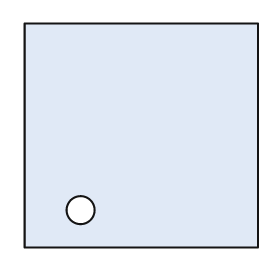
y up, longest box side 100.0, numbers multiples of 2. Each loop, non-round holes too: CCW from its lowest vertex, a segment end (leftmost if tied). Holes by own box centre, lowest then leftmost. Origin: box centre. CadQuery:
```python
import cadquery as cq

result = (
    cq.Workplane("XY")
    .moveTo(-50.0, -48.0)
    .lineTo(50.0, -48.0)
    .lineTo(50.0, 48.0)
    .lineTo(-50.0, 48.0)
    .close()
    .moveTo(-26.0, -32.0)
    .circle(6.0)
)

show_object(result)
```